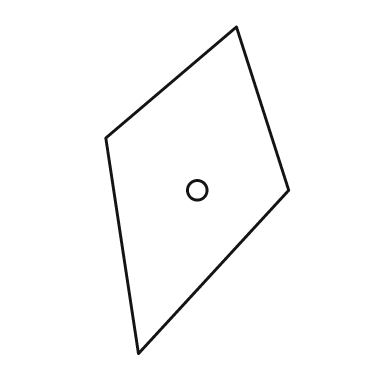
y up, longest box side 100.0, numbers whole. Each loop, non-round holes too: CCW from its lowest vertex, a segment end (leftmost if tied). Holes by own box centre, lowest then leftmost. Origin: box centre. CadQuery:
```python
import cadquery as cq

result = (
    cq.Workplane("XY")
    .moveTo(-18.0, -50.0)
    .lineTo(28.0, 0.0)
    .lineTo(12.0, 50.0)
    .lineTo(-28.0, 16.0)
    .close()
    .moveTo(0.0, 0.0)
    .circle(3.0)
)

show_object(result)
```